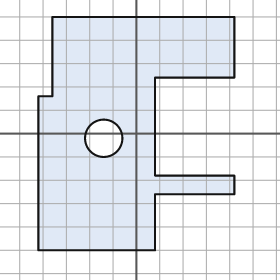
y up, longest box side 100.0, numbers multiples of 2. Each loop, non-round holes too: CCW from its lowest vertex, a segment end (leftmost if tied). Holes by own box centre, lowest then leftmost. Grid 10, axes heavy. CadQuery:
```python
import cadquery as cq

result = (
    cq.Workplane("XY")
    .moveTo(-42.0, -50.0)
    .lineTo(8.0, -50.0)
    .lineTo(8.0, -26.0)
    .lineTo(42.0, -26.0)
    .lineTo(42.0, -18.0)
    .lineTo(8.0, -18.0)
    .lineTo(8.0, 24.0)
    .lineTo(42.0, 24.0)
    .lineTo(42.0, 50.0)
    .lineTo(-36.0, 50.0)
    .lineTo(-36.0, 16.0)
    .lineTo(-42.0, 16.0)
    .close()
    .moveTo(-14.0, -2.0)
    .circle(8.0)
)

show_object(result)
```